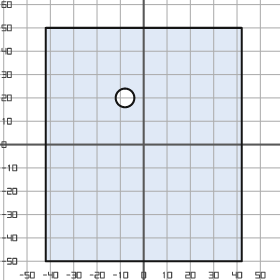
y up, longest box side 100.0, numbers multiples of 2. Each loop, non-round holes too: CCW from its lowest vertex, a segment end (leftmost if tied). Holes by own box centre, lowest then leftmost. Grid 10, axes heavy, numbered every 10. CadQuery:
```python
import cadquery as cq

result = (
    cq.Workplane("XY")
    .moveTo(-42.0, -50.0)
    .lineTo(42.0, -50.0)
    .lineTo(42.0, 50.0)
    .lineTo(-42.0, 50.0)
    .close()
    .moveTo(-8.0, 20.0)
    .circle(4.0)
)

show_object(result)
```